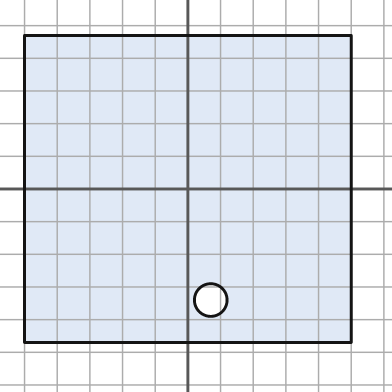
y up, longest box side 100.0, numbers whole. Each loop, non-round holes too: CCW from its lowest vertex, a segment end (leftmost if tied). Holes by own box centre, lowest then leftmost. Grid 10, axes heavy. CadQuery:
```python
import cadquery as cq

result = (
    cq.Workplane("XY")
    .moveTo(-50.0, -47.0)
    .lineTo(50.0, -47.0)
    .lineTo(50.0, 47.0)
    .lineTo(-50.0, 47.0)
    .close()
    .moveTo(7.0, -34.0)
    .circle(5.0)
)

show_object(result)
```